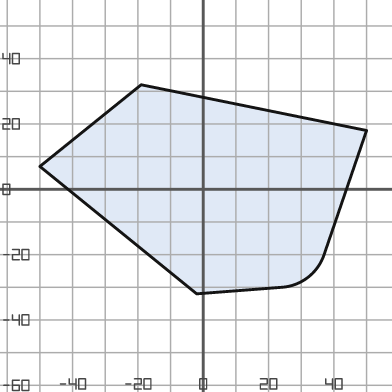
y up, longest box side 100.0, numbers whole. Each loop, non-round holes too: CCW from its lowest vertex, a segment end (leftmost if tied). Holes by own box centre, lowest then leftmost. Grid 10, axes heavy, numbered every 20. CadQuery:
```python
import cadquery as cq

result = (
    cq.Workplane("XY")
    .moveTo(-2.0, -32.0)
    .lineTo(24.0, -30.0)
    .threePointArc((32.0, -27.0), (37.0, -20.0))
    .lineTo(50.0, 18.0)
    .lineTo(-19.0, 32.0)
    .lineTo(-50.0, 7.0)
    .close()
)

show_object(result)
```